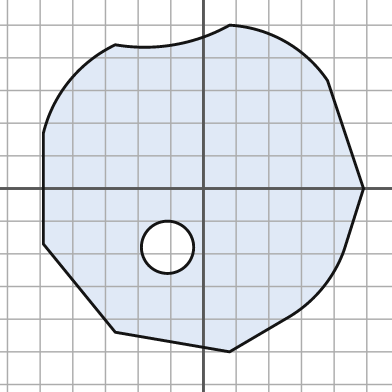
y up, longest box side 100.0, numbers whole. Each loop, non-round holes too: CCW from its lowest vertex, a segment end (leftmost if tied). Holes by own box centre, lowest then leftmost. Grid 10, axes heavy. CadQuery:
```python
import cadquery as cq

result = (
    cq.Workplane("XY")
    .moveTo(8.0, -50.0)
    .lineTo(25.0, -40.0)
    .threePointArc((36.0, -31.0), (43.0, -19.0))
    .lineTo(49.0, 0.0)
    .lineTo(38.0, 33.0)
    .threePointArc((25.0, 45.0), (8.0, 50.0))
    .threePointArc((-9.0, 44.0), (-27.0, 44.0))
    .threePointArc((-41.0, 33.0), (-49.0, 17.0))
    .lineTo(-49.0, -17.0)
    .lineTo(-27.0, -44.0)
    .close()
    .moveTo(-11.0, -18.0)
    .circle(8.0)
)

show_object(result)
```